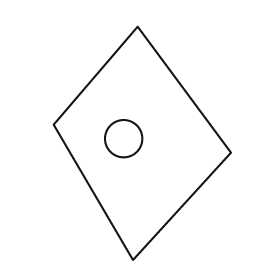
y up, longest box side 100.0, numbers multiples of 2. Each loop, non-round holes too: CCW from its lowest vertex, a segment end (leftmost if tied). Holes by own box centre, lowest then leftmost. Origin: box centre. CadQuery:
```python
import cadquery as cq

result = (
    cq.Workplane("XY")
    .moveTo(-4.0, -50.0)
    .lineTo(38.0, -4.0)
    .lineTo(-2.0, 50.0)
    .lineTo(-38.0, 8.0)
    .close()
    .moveTo(-8.0, 2.0)
    .circle(8.0)
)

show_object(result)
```